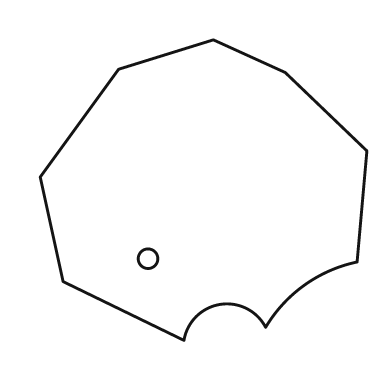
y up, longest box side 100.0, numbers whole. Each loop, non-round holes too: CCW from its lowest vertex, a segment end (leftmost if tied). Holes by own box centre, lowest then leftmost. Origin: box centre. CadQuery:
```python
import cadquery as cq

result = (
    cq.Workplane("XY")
    .moveTo(-6.0, -46.0)
    .threePointArc((5.0, -35.0), (19.0, -42.0))
    .threePointArc((31.0, -29.0), (47.0, -22.0))
    .lineTo(50.0, 12.0)
    .lineTo(25.0, 36.0)
    .lineTo(3.0, 46.0)
    .lineTo(-26.0, 37.0)
    .lineTo(-50.0, 4.0)
    .lineTo(-43.0, -28.0)
    .close()
    .moveTo(-17.0, -21.0)
    .circle(3.0)
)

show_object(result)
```